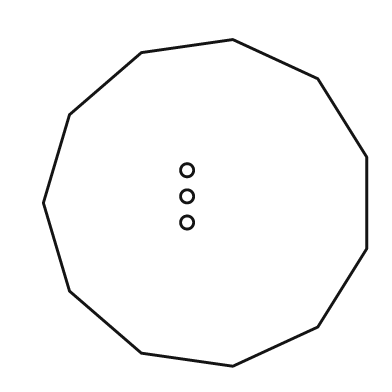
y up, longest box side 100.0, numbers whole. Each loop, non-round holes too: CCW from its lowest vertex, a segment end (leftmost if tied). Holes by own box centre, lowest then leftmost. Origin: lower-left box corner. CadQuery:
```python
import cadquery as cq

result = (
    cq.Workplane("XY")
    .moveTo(58.0, 0.0)
    .lineTo(84.0, 12.0)
    .lineTo(99.0, 36.0)
    .lineTo(99.0, 64.0)
    .lineTo(84.0, 88.0)
    .lineTo(58.0, 100.0)
    .lineTo(30.0, 96.0)
    .lineTo(8.0, 77.0)
    .lineTo(0.0, 50.0)
    .lineTo(8.0, 23.0)
    .lineTo(30.0, 4.0)
    .close()
    .moveTo(44.0, 44.0)
    .circle(2.0)
    .moveTo(44.0, 52.0)
    .circle(2.0)
    .moveTo(44.0, 60.0)
    .circle(2.0)
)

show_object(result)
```